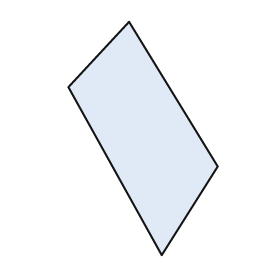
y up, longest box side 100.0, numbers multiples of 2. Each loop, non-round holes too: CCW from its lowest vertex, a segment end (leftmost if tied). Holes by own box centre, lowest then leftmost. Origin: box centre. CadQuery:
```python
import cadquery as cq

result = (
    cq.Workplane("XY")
    .moveTo(8.0, -50.0)
    .lineTo(32.0, -12.0)
    .lineTo(-6.0, 50.0)
    .lineTo(-32.0, 22.0)
    .close()
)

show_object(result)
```